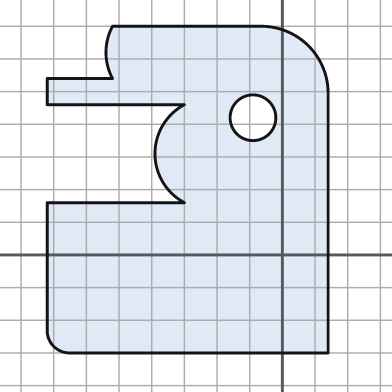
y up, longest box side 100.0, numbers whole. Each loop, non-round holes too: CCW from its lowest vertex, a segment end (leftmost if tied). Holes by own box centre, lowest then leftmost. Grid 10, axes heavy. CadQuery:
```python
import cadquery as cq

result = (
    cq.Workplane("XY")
    .moveTo(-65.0, -30.0)
    .lineTo(14.0, -30.0)
    .lineTo(14.0, 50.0)
    .threePointArc((8.0, 64.0), (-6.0, 70.0))
    .lineTo(-52.0, 70.0)
    .threePointArc((-54.0, 62.0), (-52.0, 54.0))
    .lineTo(-72.0, 54.0)
    .lineTo(-72.0, 46.0)
    .lineTo(-30.0, 46.0)
    .threePointArc((-39.0, 31.0), (-30.0, 16.0))
    .lineTo(-72.0, 16.0)
    .lineTo(-72.0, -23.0)
    .threePointArc((-70.0, -28.0), (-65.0, -30.0))
    .close()
    .moveTo(-9.0, 42.0)
    .circle(7.0)
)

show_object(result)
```